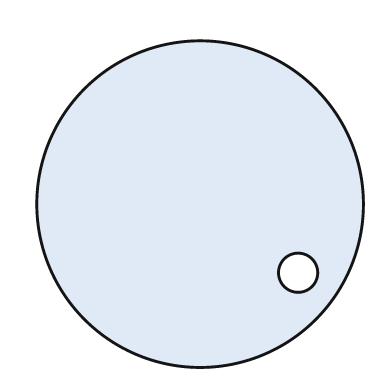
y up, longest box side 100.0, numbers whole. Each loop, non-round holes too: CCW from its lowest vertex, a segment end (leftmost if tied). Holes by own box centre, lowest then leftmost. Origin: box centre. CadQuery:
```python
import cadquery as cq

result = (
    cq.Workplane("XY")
    .moveTo(0.0, 0.0)
    .circle(50.0)
    .moveTo(30.0, -21.0)
    .circle(6.0)
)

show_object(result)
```